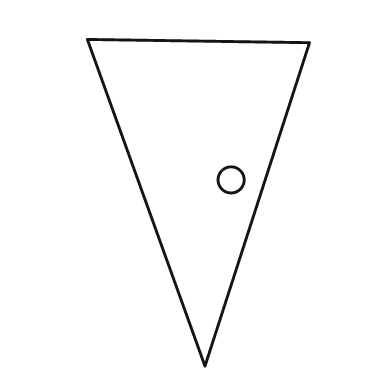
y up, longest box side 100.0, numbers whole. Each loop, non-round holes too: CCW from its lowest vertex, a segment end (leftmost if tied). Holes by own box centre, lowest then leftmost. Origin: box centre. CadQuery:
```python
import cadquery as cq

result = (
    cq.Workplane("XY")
    .moveTo(2.0, -50.0)
    .lineTo(34.0, 49.0)
    .lineTo(-34.0, 50.0)
    .close()
    .moveTo(10.0, 7.0)
    .circle(4.0)
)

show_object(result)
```